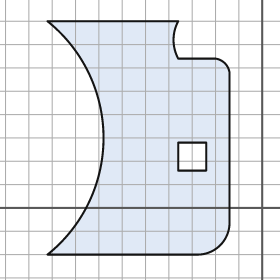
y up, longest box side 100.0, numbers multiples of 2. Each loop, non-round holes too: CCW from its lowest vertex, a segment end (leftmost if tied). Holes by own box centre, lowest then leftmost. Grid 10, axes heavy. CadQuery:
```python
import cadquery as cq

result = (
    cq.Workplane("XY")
    .moveTo(-92.0, -20.0)
    .lineTo(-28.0, -20.0)
    .threePointArc((-18.0, -16.0), (-14.0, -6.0))
    .lineTo(-14.0, 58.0)
    .threePointArc((-16.0, 62.0), (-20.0, 64.0))
    .lineTo(-36.0, 64.0)
    .threePointArc((-38.0, 72.0), (-36.0, 80.0))
    .lineTo(-92.0, 80.0)
    .threePointArc((-68.0, 30.0), (-92.0, -20.0))
    .close()
    .moveTo(-36.0, 16.0)
    .lineTo(-24.0, 16.0)
    .lineTo(-24.0, 28.0)
    .lineTo(-36.0, 28.0)
    .close()
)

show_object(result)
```